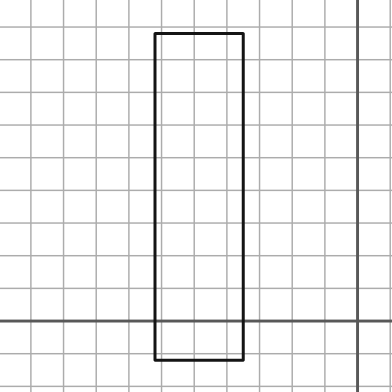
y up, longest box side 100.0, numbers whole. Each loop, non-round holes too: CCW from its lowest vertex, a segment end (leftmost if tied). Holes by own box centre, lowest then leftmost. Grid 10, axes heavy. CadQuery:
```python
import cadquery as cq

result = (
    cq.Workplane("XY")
    .moveTo(-62.0, -12.0)
    .lineTo(-35.0, -12.0)
    .lineTo(-35.0, 88.0)
    .lineTo(-62.0, 88.0)
    .close()
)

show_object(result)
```